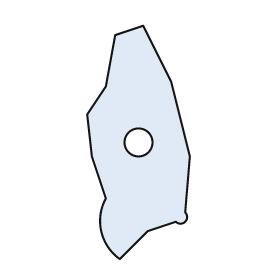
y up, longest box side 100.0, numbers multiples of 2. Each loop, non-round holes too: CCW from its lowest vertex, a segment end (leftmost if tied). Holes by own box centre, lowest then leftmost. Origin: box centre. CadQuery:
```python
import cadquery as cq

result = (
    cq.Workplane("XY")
    .moveTo(-8.0, -50.0)
    .lineTo(4.0, -38.0)
    .lineTo(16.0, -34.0)
    .threePointArc((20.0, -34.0), (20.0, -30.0))
    .lineTo(22.0, -6.0)
    .lineTo(14.0, 26.0)
    .lineTo(2.0, 50.0)
    .lineTo(-10.0, 46.0)
    .lineTo(-14.0, 24.0)
    .lineTo(-22.0, 12.0)
    .lineTo(-20.0, -6.0)
    .lineTo(-14.0, -24.0)
    .threePointArc((-16.0, -38.0), (-8.0, -50.0))
    .close()
    .moveTo(0.0, 0.0)
    .circle(6.0)
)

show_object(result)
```